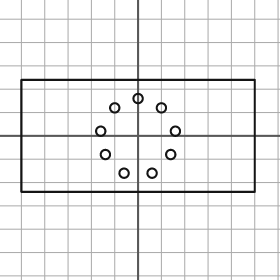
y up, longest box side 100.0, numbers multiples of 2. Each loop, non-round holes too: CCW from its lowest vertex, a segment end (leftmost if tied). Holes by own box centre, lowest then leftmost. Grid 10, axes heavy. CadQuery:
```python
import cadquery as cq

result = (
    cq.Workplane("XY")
    .moveTo(-50.0, -24.0)
    .lineTo(50.0, -24.0)
    .lineTo(50.0, 24.0)
    .lineTo(-50.0, 24.0)
    .close()
    .moveTo(-6.0, -16.0)
    .circle(2.0)
    .moveTo(6.0, -16.0)
    .circle(2.0)
    .moveTo(-14.0, -8.0)
    .circle(2.0)
    .moveTo(14.0, -8.0)
    .circle(2.0)
    .moveTo(-16.0, 2.0)
    .circle(2.0)
    .moveTo(16.0, 2.0)
    .circle(2.0)
    .moveTo(-10.0, 12.0)
    .circle(2.0)
    .moveTo(10.0, 12.0)
    .circle(2.0)
    .moveTo(0.0, 16.0)
    .circle(2.0)
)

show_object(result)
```